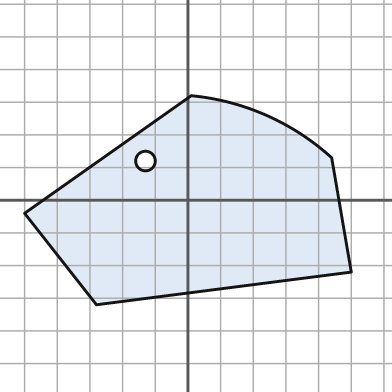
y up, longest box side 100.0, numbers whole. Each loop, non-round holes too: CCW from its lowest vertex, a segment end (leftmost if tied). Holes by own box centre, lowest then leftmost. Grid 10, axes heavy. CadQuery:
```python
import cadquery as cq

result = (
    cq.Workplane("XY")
    .moveTo(-28.0, -32.0)
    .lineTo(50.0, -22.0)
    .lineTo(44.0, 13.0)
    .threePointArc((24.0, 26.0), (1.0, 32.0))
    .lineTo(-50.0, -4.0)
    .close()
    .moveTo(-13.0, 12.0)
    .circle(3.0)
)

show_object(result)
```